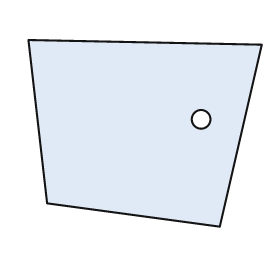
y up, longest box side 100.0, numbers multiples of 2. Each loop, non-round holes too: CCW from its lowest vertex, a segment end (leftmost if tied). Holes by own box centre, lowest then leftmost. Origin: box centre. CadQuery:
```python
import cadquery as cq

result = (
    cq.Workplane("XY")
    .moveTo(32.0, -40.0)
    .lineTo(50.0, 38.0)
    .lineTo(-50.0, 40.0)
    .lineTo(-42.0, -30.0)
    .close()
    .moveTo(24.0, 6.0)
    .circle(4.0)
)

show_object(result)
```